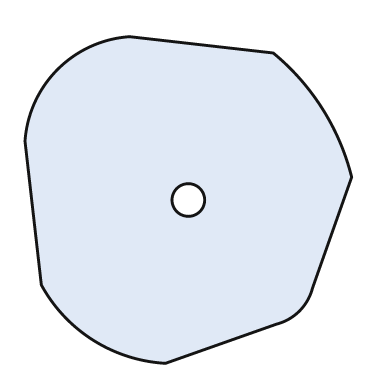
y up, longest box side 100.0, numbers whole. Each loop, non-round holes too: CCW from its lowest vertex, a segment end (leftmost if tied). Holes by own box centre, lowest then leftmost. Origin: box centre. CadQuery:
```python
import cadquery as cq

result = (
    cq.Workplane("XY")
    .moveTo(-7.0, -50.0)
    .lineTo(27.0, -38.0)
    .threePointArc((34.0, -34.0), (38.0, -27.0))
    .lineTo(50.0, 7.0)
    .threePointArc((41.0, 28.0), (26.0, 45.0))
    .lineTo(-18.0, 50.0)
    .threePointArc((-40.0, 40.0), (-50.0, 18.0))
    .lineTo(-45.0, -26.0)
    .threePointArc((-29.0, -43.0), (-7.0, -50.0))
    .close()
    .moveTo(0.0, 0.0)
    .circle(5.0)
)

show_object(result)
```